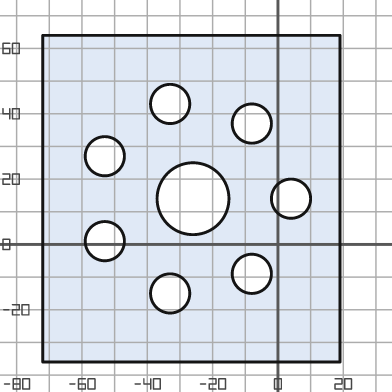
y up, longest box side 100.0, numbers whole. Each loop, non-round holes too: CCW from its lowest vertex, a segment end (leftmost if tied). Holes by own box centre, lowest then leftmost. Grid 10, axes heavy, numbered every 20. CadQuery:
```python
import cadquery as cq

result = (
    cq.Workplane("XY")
    .moveTo(-72.0, -36.0)
    .lineTo(19.0, -36.0)
    .lineTo(19.0, 64.0)
    .lineTo(-72.0, 64.0)
    .close()
    .moveTo(-33.0, -15.0)
    .circle(6.0)
    .moveTo(-8.0, -9.0)
    .circle(6.0)
    .moveTo(-53.0, 1.0)
    .circle(6.0)
    .moveTo(-26.0, 14.0)
    .circle(11.0)
    .moveTo(4.0, 14.0)
    .circle(6.0)
    .moveTo(-53.0, 27.0)
    .circle(6.0)
    .moveTo(-8.0, 37.0)
    .circle(6.0)
    .moveTo(-33.0, 43.0)
    .circle(6.0)
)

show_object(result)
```